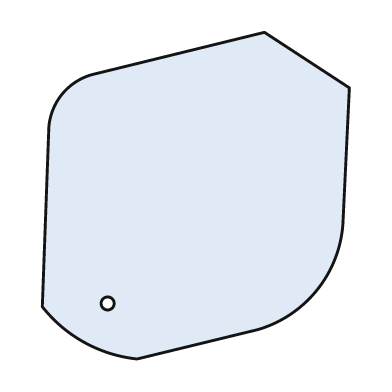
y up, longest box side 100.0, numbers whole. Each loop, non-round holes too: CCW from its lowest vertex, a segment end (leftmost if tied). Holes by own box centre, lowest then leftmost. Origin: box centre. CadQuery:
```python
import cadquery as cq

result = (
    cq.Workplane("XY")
    .moveTo(-18.0, -50.0)
    .lineTo(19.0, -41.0)
    .threePointArc((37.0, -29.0), (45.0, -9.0))
    .lineTo(47.0, 33.0)
    .lineTo(21.0, 50.0)
    .lineTo(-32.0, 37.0)
    .threePointArc((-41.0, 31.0), (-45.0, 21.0))
    .lineTo(-47.0, -34.0)
    .threePointArc((-34.0, -45.0), (-18.0, -50.0))
    .close()
    .moveTo(-27.0, -33.0)
    .circle(2.0)
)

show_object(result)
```